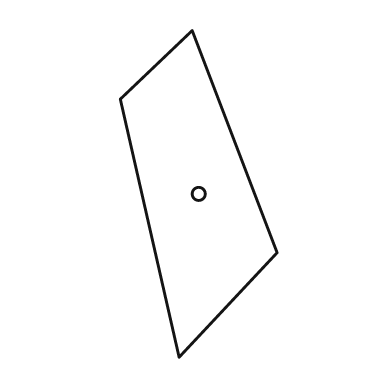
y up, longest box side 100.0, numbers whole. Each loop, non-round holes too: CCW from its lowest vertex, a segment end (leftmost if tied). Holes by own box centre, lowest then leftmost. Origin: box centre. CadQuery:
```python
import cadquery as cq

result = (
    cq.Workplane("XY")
    .moveTo(-6.0, -50.0)
    .lineTo(24.0, -18.0)
    .lineTo(-2.0, 50.0)
    .lineTo(-24.0, 29.0)
    .close()
    .moveTo(0.0, 0.0)
    .circle(2.0)
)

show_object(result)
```